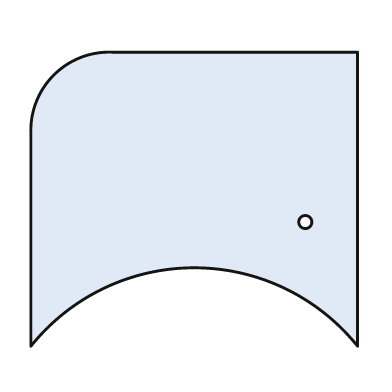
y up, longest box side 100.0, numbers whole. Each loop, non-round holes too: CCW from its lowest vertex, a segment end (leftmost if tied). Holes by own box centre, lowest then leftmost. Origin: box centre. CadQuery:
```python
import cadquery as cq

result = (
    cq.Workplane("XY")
    .moveTo(-50.0, -45.0)
    .threePointArc((0.0, -21.0), (50.0, -45.0))
    .lineTo(50.0, 45.0)
    .lineTo(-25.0, 45.0)
    .threePointArc((-43.0, 38.0), (-50.0, 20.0))
    .close()
    .moveTo(34.0, -7.0)
    .circle(2.0)
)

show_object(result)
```